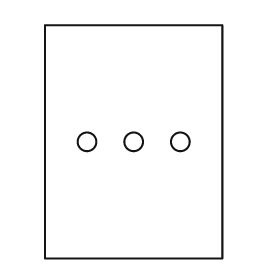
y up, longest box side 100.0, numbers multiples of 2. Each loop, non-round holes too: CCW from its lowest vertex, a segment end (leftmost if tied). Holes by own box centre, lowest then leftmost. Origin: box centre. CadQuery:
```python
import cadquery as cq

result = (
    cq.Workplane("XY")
    .moveTo(-38.0, -50.0)
    .lineTo(38.0, -50.0)
    .lineTo(38.0, 50.0)
    .lineTo(-38.0, 50.0)
    .close()
    .moveTo(-20.0, 0.0)
    .circle(4.0)
    .moveTo(0.0, 0.0)
    .circle(4.0)
    .moveTo(20.0, 0.0)
    .circle(4.0)
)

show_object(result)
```